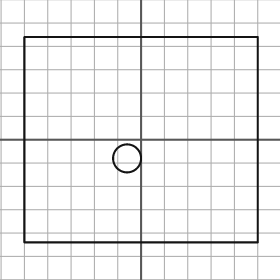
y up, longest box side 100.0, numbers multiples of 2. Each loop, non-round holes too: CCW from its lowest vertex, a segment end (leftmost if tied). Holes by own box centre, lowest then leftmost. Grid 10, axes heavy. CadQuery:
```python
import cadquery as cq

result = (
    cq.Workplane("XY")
    .moveTo(-50.0, -44.0)
    .lineTo(50.0, -44.0)
    .lineTo(50.0, 44.0)
    .lineTo(-50.0, 44.0)
    .close()
    .moveTo(-6.0, -8.0)
    .circle(6.0)
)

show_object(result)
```